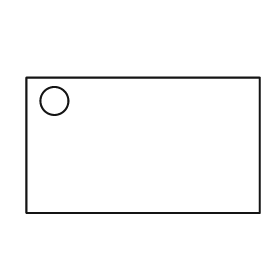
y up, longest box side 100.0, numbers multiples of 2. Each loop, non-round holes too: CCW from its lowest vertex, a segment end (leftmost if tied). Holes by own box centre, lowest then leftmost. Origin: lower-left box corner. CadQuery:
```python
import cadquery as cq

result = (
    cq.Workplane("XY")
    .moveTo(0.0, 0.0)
    .lineTo(100.0, 0.0)
    .lineTo(100.0, 58.0)
    .lineTo(0.0, 58.0)
    .close()
    .moveTo(12.0, 48.0)
    .circle(6.0)
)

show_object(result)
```